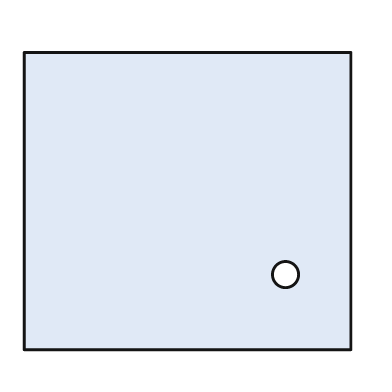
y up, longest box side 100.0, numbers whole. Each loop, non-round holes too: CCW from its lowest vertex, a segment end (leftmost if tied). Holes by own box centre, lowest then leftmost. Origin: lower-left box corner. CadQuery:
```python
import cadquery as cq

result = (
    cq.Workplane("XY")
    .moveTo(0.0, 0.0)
    .lineTo(100.0, 0.0)
    .lineTo(100.0, 91.0)
    .lineTo(0.0, 91.0)
    .close()
    .moveTo(80.0, 23.0)
    .circle(4.0)
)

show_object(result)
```